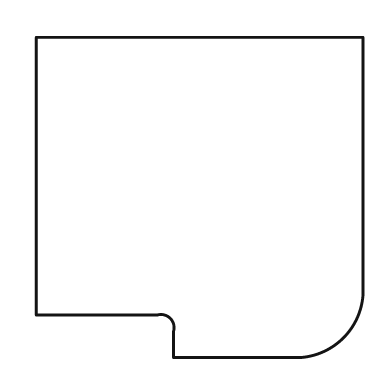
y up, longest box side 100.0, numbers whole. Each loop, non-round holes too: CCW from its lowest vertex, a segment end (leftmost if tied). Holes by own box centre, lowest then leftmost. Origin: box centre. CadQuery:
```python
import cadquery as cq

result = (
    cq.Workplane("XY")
    .moveTo(-8.0, -49.0)
    .lineTo(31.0, -49.0)
    .threePointArc((44.0, -43.0), (50.0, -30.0))
    .lineTo(50.0, 49.0)
    .lineTo(-50.0, 49.0)
    .lineTo(-50.0, -36.0)
    .lineTo(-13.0, -36.0)
    .threePointArc((-9.0, -37.0), (-8.0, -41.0))
    .close()
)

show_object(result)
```